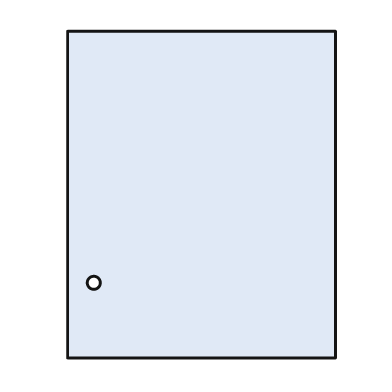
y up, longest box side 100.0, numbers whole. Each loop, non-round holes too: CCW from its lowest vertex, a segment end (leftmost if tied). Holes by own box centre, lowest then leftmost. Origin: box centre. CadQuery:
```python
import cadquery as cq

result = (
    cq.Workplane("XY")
    .moveTo(-41.0, -50.0)
    .lineTo(41.0, -50.0)
    .lineTo(41.0, 50.0)
    .lineTo(-41.0, 50.0)
    .close()
    .moveTo(-33.0, -27.0)
    .circle(2.0)
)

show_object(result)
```